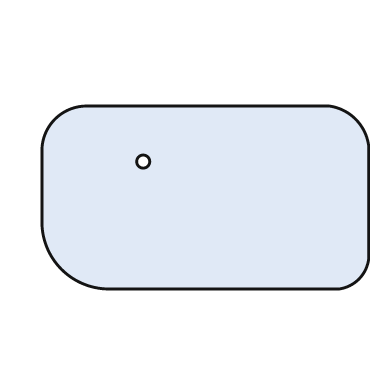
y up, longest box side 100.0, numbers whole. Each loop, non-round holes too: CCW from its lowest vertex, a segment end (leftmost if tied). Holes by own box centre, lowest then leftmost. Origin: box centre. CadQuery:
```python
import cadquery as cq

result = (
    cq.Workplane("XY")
    .moveTo(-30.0, -28.0)
    .lineTo(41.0, -28.0)
    .threePointArc((47.0, -25.0), (50.0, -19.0))
    .lineTo(50.0, 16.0)
    .threePointArc((46.0, 24.0), (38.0, 28.0))
    .lineTo(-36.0, 28.0)
    .threePointArc((-46.0, 24.0), (-50.0, 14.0))
    .lineTo(-50.0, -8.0)
    .threePointArc((-44.0, -22.0), (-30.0, -28.0))
    .close()
    .moveTo(-19.0, 11.0)
    .circle(2.0)
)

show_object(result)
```